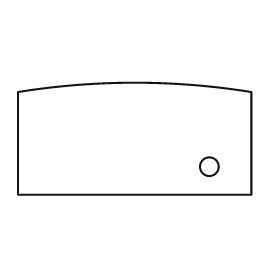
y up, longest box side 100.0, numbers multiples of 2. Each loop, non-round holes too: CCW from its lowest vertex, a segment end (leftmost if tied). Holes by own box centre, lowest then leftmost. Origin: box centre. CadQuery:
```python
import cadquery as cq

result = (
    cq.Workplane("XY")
    .moveTo(-50.0, -24.0)
    .lineTo(50.0, -24.0)
    .lineTo(50.0, 20.0)
    .threePointArc((0.0, 24.0), (-50.0, 20.0))
    .close()
    .moveTo(32.0, -12.0)
    .circle(4.0)
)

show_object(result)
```